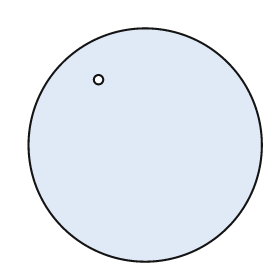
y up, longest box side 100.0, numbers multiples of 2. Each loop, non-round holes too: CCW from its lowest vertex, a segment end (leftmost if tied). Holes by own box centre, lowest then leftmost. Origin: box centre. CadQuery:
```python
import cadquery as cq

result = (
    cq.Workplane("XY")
    .moveTo(0.0, 0.0)
    .circle(50.0)
    .moveTo(-20.0, 28.0)
    .circle(2.0)
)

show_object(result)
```